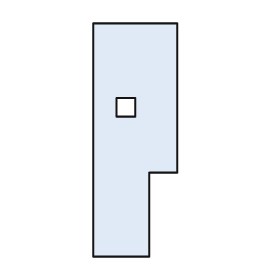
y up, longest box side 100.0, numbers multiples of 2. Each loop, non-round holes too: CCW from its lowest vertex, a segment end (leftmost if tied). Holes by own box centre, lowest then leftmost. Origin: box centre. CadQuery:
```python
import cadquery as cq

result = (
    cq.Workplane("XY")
    .moveTo(-18.0, -50.0)
    .lineTo(6.0, -50.0)
    .lineTo(6.0, -14.0)
    .lineTo(18.0, -14.0)
    .lineTo(18.0, 50.0)
    .lineTo(-18.0, 50.0)
    .close()
    .moveTo(-8.0, 10.0)
    .lineTo(0.0, 10.0)
    .lineTo(0.0, 18.0)
    .lineTo(-8.0, 18.0)
    .close()
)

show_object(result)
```